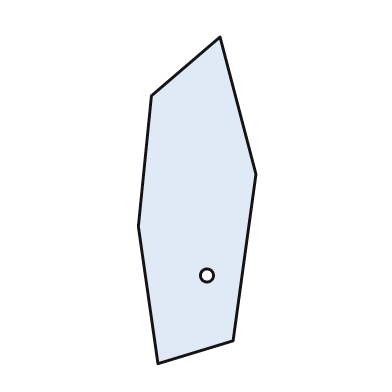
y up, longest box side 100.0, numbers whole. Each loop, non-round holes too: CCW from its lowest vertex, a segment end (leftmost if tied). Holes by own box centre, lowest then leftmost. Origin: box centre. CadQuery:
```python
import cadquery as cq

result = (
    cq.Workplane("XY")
    .moveTo(-12.0, -50.0)
    .lineTo(11.0, -43.0)
    .lineTo(18.0, 8.0)
    .lineTo(7.0, 50.0)
    .lineTo(-14.0, 32.0)
    .lineTo(-18.0, -8.0)
    .close()
    .moveTo(3.0, -23.0)
    .circle(2.0)
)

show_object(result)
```